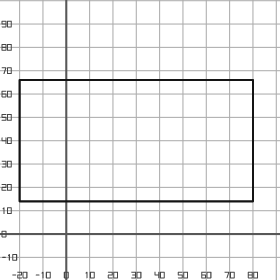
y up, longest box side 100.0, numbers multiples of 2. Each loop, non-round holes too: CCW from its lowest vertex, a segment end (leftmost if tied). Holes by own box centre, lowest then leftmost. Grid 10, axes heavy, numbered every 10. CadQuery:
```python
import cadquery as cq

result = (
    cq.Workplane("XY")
    .moveTo(-20.0, 14.0)
    .lineTo(80.0, 14.0)
    .lineTo(80.0, 66.0)
    .lineTo(-20.0, 66.0)
    .close()
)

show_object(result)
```